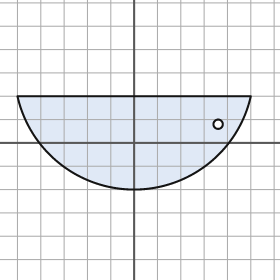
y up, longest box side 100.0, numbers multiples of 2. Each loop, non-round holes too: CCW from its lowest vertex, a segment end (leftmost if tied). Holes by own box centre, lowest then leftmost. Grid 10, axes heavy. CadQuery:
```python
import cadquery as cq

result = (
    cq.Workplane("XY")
    .moveTo(-50.0, 20.0)
    .threePointArc((0.0, -20.0), (50.0, 20.0))
    .close()
    .moveTo(36.0, 8.0)
    .circle(2.0)
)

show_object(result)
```